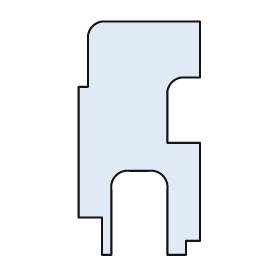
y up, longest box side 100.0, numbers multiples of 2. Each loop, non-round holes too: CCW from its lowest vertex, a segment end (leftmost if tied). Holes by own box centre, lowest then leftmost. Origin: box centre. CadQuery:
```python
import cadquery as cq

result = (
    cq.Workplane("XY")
    .moveTo(-16.0, -50.0)
    .lineTo(-12.0, -50.0)
    .lineTo(-12.0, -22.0)
    .threePointArc((-10.0, -16.0), (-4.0, -14.0))
    .lineTo(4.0, -14.0)
    .threePointArc((10.0, -16.0), (12.0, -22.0))
    .lineTo(12.0, -50.0)
    .lineTo(20.0, -50.0)
    .lineTo(20.0, -44.0)
    .lineTo(26.0, -44.0)
    .lineTo(26.0, -2.0)
    .lineTo(12.0, -2.0)
    .lineTo(12.0, 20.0)
    .threePointArc((14.0, 24.0), (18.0, 26.0))
    .lineTo(26.0, 26.0)
    .lineTo(26.0, 50.0)
    .lineTo(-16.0, 50.0)
    .threePointArc((-20.0, 48.0), (-22.0, 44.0))
    .lineTo(-22.0, 22.0)
    .lineTo(-26.0, 22.0)
    .lineTo(-26.0, -34.0)
    .lineTo(-16.0, -34.0)
    .close()
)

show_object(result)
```